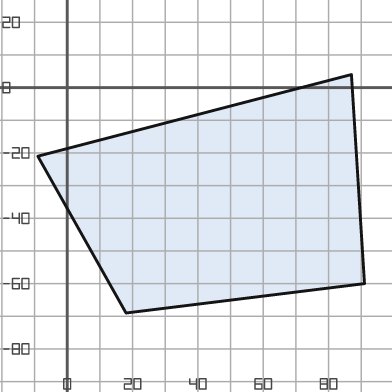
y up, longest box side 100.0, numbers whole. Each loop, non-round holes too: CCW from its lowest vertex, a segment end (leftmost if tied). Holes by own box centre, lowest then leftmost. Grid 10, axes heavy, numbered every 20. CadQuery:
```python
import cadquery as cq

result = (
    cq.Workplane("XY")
    .moveTo(18.0, -69.0)
    .lineTo(91.0, -60.0)
    .lineTo(87.0, 4.0)
    .lineTo(-9.0, -21.0)
    .close()
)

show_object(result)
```